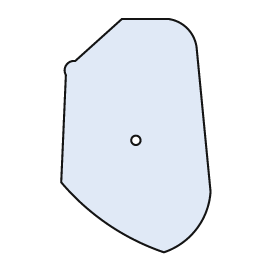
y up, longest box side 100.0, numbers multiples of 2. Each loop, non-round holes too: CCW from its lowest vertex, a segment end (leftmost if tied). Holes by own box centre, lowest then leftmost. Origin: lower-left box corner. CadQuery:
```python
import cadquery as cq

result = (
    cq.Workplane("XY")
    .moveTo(44.0, 0.0)
    .threePointArc((58.0, 10.0), (64.0, 26.0))
    .lineTo(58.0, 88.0)
    .threePointArc((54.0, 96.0), (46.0, 100.0))
    .lineTo(26.0, 100.0)
    .lineTo(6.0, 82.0)
    .threePointArc((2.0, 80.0), (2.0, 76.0))
    .lineTo(0.0, 30.0)
    .threePointArc((20.0, 12.0), (44.0, 0.0))
    .close()
    .moveTo(32.0, 48.0)
    .circle(2.0)
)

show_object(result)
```